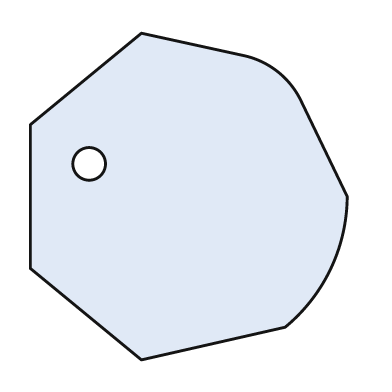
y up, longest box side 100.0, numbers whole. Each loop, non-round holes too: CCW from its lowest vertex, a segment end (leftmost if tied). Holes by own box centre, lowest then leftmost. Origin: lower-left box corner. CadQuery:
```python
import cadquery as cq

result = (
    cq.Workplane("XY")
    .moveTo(34.0, 0.0)
    .lineTo(78.0, 10.0)
    .threePointArc((92.0, 28.0), (97.0, 50.0))
    .lineTo(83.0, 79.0)
    .threePointArc((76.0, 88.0), (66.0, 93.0))
    .lineTo(34.0, 100.0)
    .lineTo(0.0, 72.0)
    .lineTo(0.0, 28.0)
    .close()
    .moveTo(18.0, 60.0)
    .circle(5.0)
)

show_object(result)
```